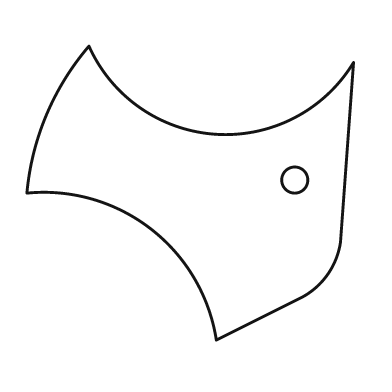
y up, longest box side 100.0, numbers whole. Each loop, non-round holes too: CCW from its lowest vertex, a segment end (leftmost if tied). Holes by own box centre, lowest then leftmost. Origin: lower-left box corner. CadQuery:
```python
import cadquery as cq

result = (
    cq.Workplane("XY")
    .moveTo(58.0, 0.0)
    .lineTo(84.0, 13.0)
    .threePointArc((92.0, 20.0), (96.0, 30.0))
    .lineTo(100.0, 85.0)
    .threePointArc((58.0, 63.0), (19.0, 90.0))
    .threePointArc((6.0, 69.0), (0.0, 45.0))
    .threePointArc((38.0, 34.0), (58.0, 0.0))
    .close()
    .moveTo(82.0, 49.0)
    .circle(4.0)
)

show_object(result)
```